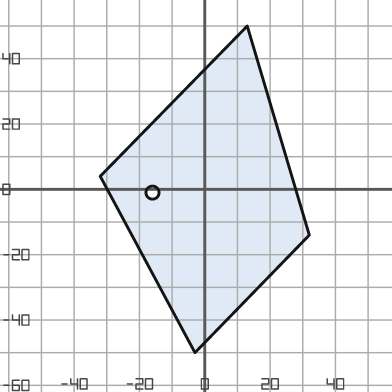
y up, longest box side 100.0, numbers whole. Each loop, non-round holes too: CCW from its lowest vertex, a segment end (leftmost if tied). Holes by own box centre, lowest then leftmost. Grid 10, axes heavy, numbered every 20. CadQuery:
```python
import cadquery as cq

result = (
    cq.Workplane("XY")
    .moveTo(-3.0, -50.0)
    .lineTo(32.0, -14.0)
    .lineTo(13.0, 50.0)
    .lineTo(-32.0, 4.0)
    .close()
    .moveTo(-16.0, -1.0)
    .circle(2.0)
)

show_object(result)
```